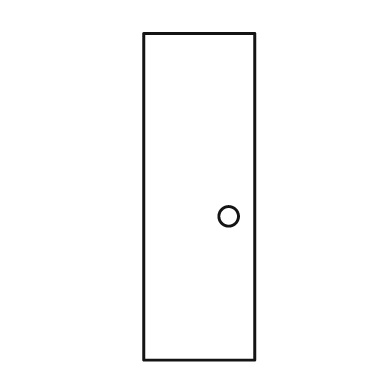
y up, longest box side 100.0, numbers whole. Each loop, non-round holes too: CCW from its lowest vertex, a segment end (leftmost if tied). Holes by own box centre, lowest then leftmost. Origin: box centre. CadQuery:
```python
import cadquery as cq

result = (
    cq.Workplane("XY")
    .moveTo(-17.0, -50.0)
    .lineTo(17.0, -50.0)
    .lineTo(17.0, 50.0)
    .lineTo(-17.0, 50.0)
    .close()
    .moveTo(9.0, -6.0)
    .circle(3.0)
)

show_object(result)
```